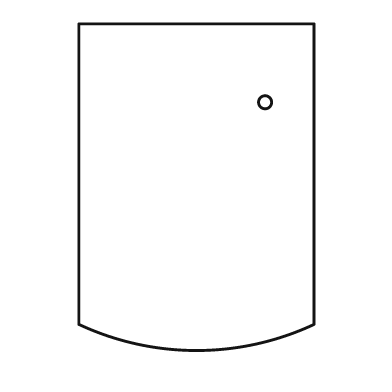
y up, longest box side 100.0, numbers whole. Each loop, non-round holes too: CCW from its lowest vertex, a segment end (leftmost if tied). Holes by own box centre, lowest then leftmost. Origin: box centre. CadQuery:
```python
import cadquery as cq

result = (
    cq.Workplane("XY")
    .moveTo(-36.0, -42.0)
    .threePointArc((0.0, -50.0), (36.0, -42.0))
    .lineTo(36.0, 50.0)
    .lineTo(-36.0, 50.0)
    .close()
    .moveTo(21.0, 26.0)
    .circle(2.0)
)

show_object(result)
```